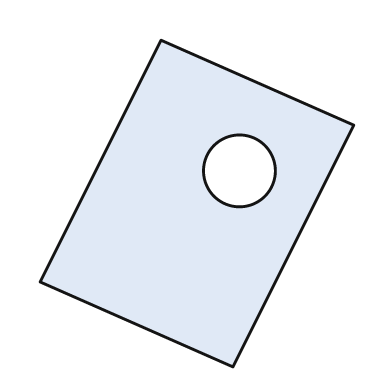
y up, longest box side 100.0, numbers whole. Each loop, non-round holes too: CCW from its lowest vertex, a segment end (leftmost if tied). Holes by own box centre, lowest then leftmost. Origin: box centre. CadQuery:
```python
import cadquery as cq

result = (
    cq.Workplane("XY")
    .moveTo(11.0, -50.0)
    .lineTo(48.0, 24.0)
    .lineTo(-11.0, 50.0)
    .lineTo(-48.0, -24.0)
    .close()
    .moveTo(13.0, 10.0)
    .circle(11.0)
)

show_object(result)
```